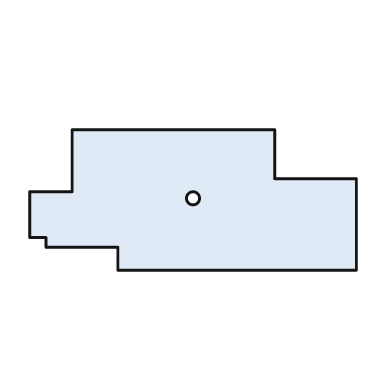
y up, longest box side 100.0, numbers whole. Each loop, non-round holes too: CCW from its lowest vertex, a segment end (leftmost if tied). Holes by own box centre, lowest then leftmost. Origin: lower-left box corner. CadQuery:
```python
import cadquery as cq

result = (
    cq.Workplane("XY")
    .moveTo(27.0, 0.0)
    .lineTo(100.0, 0.0)
    .lineTo(100.0, 28.0)
    .lineTo(75.0, 28.0)
    .lineTo(75.0, 43.0)
    .lineTo(13.0, 43.0)
    .lineTo(13.0, 24.0)
    .lineTo(0.0, 24.0)
    .lineTo(0.0, 10.0)
    .lineTo(5.0, 10.0)
    .lineTo(5.0, 7.0)
    .lineTo(27.0, 7.0)
    .close()
    .moveTo(50.0, 22.0)
    .circle(2.0)
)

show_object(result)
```